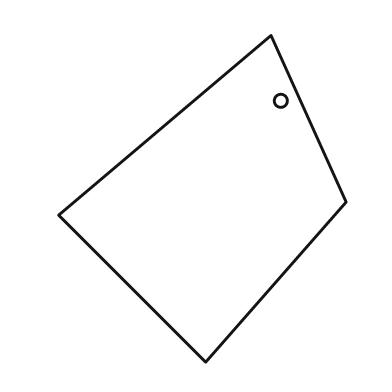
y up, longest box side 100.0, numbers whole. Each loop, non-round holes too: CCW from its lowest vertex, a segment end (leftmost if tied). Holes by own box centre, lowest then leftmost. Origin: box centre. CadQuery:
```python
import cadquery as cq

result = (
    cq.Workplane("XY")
    .moveTo(1.0, -50.0)
    .lineTo(44.0, -1.0)
    .lineTo(21.0, 50.0)
    .lineTo(-44.0, -5.0)
    .close()
    .moveTo(24.0, 30.0)
    .circle(2.0)
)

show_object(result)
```